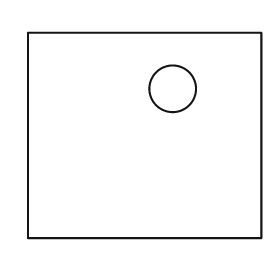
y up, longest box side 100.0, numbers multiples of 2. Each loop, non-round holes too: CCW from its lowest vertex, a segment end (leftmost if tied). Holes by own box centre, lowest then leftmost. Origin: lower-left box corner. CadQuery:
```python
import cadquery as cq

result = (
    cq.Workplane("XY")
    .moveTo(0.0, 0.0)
    .lineTo(100.0, 0.0)
    .lineTo(100.0, 88.0)
    .lineTo(0.0, 88.0)
    .close()
    .moveTo(62.0, 64.0)
    .circle(10.0)
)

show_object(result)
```